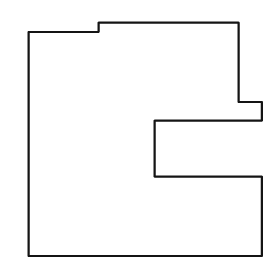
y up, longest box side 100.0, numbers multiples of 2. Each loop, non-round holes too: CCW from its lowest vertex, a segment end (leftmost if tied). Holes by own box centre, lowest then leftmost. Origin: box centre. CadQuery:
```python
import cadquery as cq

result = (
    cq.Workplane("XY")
    .moveTo(-50.0, -50.0)
    .lineTo(50.0, -50.0)
    .lineTo(50.0, -16.0)
    .lineTo(4.0, -16.0)
    .lineTo(4.0, 8.0)
    .lineTo(50.0, 8.0)
    .lineTo(50.0, 16.0)
    .lineTo(40.0, 16.0)
    .lineTo(40.0, 50.0)
    .lineTo(-20.0, 50.0)
    .lineTo(-20.0, 46.0)
    .lineTo(-50.0, 46.0)
    .close()
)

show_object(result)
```